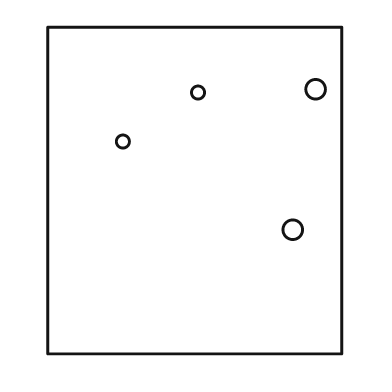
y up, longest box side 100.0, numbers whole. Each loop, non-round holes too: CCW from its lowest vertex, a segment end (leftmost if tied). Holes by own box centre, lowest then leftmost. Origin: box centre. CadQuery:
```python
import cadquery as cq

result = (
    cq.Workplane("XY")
    .moveTo(-45.0, -50.0)
    .lineTo(45.0, -50.0)
    .lineTo(45.0, 50.0)
    .lineTo(-45.0, 50.0)
    .close()
    .moveTo(30.0, -12.0)
    .circle(3.0)
    .moveTo(-22.0, 15.0)
    .circle(2.0)
    .moveTo(1.0, 30.0)
    .circle(2.0)
    .moveTo(37.0, 31.0)
    .circle(3.0)
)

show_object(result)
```